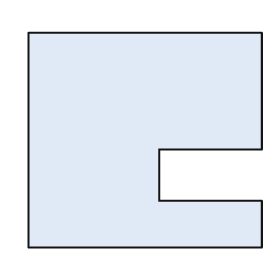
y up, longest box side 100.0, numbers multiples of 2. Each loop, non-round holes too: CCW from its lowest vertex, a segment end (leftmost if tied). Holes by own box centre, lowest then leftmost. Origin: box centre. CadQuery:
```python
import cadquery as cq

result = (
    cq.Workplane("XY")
    .moveTo(-50.0, -46.0)
    .lineTo(50.0, -46.0)
    .lineTo(50.0, -26.0)
    .lineTo(6.0, -26.0)
    .lineTo(6.0, -4.0)
    .lineTo(50.0, -4.0)
    .lineTo(50.0, 46.0)
    .lineTo(-50.0, 46.0)
    .close()
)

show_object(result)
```